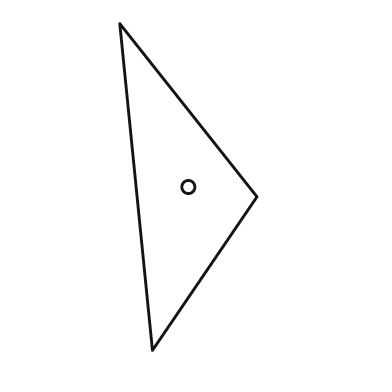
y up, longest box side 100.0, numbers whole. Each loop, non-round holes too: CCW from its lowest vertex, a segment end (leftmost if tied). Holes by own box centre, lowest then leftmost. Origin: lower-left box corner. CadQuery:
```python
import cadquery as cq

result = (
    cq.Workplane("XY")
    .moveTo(10.0, 0.0)
    .lineTo(42.0, 47.0)
    .lineTo(0.0, 100.0)
    .close()
    .moveTo(21.0, 50.0)
    .circle(2.0)
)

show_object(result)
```